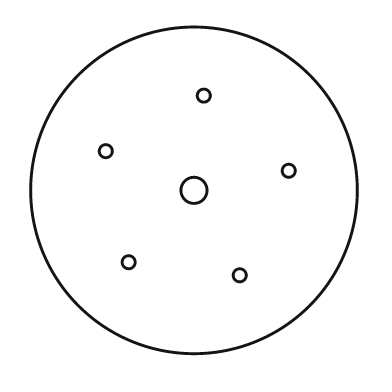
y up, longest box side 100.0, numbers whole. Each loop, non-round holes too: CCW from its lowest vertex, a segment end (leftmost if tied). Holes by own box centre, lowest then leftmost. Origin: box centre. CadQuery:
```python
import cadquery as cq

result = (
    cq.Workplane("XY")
    .moveTo(0.0, 0.0)
    .circle(50.0)
    .moveTo(14.0, -26.0)
    .circle(2.0)
    .moveTo(-20.0, -22.0)
    .circle(2.0)
    .moveTo(0.0, 0.0)
    .circle(4.0)
    .moveTo(29.0, 6.0)
    .circle(2.0)
    .moveTo(-27.0, 12.0)
    .circle(2.0)
    .moveTo(3.0, 29.0)
    .circle(2.0)
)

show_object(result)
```